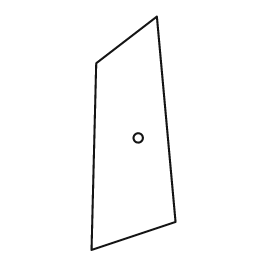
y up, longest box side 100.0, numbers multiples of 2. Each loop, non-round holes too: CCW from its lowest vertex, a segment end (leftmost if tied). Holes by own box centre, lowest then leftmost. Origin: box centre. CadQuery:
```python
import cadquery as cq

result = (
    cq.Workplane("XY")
    .moveTo(-18.0, -50.0)
    .lineTo(18.0, -38.0)
    .lineTo(10.0, 50.0)
    .lineTo(-16.0, 30.0)
    .close()
    .moveTo(2.0, -2.0)
    .circle(2.0)
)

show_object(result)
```